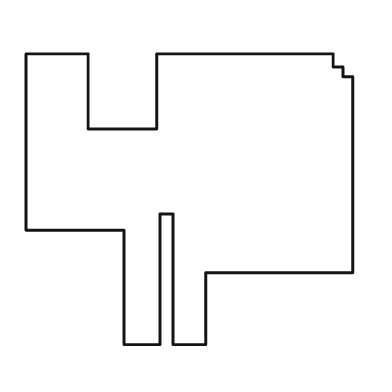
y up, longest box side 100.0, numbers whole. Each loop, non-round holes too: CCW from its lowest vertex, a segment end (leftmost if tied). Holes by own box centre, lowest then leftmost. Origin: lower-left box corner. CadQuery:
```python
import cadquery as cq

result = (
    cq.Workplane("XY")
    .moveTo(30.0, 0.0)
    .lineTo(41.0, 0.0)
    .lineTo(41.0, 40.0)
    .lineTo(45.0, 40.0)
    .lineTo(45.0, 0.0)
    .lineTo(55.0, 0.0)
    .lineTo(55.0, 22.0)
    .lineTo(100.0, 22.0)
    .lineTo(100.0, 82.0)
    .lineTo(97.0, 82.0)
    .lineTo(97.0, 85.0)
    .lineTo(94.0, 85.0)
    .lineTo(94.0, 89.0)
    .lineTo(40.0, 89.0)
    .lineTo(40.0, 66.0)
    .lineTo(19.0, 66.0)
    .lineTo(19.0, 89.0)
    .lineTo(0.0, 89.0)
    .lineTo(0.0, 35.0)
    .lineTo(30.0, 35.0)
    .close()
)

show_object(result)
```